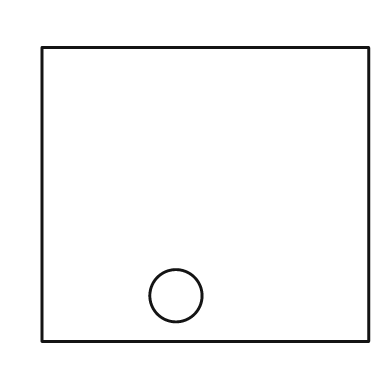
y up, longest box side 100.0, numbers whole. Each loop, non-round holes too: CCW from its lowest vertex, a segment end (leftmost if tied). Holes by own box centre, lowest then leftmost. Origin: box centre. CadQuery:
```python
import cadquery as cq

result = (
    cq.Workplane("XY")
    .moveTo(-50.0, -45.0)
    .lineTo(50.0, -45.0)
    .lineTo(50.0, 45.0)
    .lineTo(-50.0, 45.0)
    .close()
    .moveTo(-9.0, -31.0)
    .circle(8.0)
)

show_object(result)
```